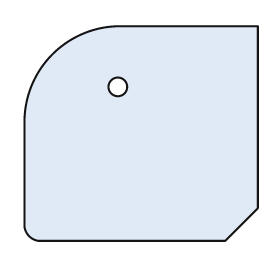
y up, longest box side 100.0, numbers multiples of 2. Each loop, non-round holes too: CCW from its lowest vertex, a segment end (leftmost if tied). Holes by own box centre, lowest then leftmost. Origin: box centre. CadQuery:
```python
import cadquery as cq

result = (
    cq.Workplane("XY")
    .moveTo(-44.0, -46.0)
    .lineTo(36.0, -46.0)
    .lineTo(50.0, -32.0)
    .lineTo(50.0, 46.0)
    .lineTo(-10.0, 46.0)
    .threePointArc((-38.0, 34.0), (-50.0, 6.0))
    .lineTo(-50.0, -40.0)
    .threePointArc((-48.0, -44.0), (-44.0, -46.0))
    .close()
    .moveTo(-10.0, 20.0)
    .circle(4.0)
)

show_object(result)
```